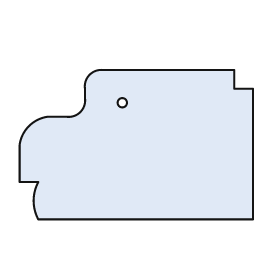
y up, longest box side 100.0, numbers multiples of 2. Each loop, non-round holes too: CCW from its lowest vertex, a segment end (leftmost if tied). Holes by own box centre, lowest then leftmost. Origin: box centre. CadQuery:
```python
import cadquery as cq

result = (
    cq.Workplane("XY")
    .moveTo(-42.0, -32.0)
    .lineTo(50.0, -32.0)
    .lineTo(50.0, 24.0)
    .lineTo(42.0, 24.0)
    .lineTo(42.0, 32.0)
    .lineTo(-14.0, 32.0)
    .threePointArc((-20.0, 30.0), (-22.0, 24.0))
    .lineTo(-22.0, 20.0)
    .threePointArc((-24.0, 14.0), (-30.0, 12.0))
    .lineTo(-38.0, 12.0)
    .threePointArc((-46.0, 8.0), (-50.0, 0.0))
    .lineTo(-50.0, -16.0)
    .lineTo(-42.0, -16.0)
    .threePointArc((-44.0, -24.0), (-42.0, -32.0))
    .close()
    .moveTo(-6.0, 18.0)
    .circle(2.0)
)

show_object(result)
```